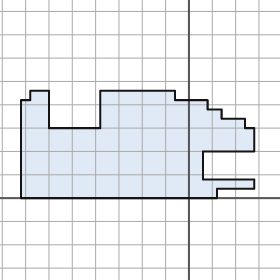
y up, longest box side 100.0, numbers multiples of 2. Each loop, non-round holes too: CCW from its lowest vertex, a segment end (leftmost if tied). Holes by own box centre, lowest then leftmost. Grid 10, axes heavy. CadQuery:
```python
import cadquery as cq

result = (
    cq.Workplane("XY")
    .moveTo(-72.0, 0.0)
    .lineTo(12.0, 0.0)
    .lineTo(12.0, 4.0)
    .lineTo(28.0, 4.0)
    .lineTo(28.0, 8.0)
    .lineTo(6.0, 8.0)
    .lineTo(6.0, 20.0)
    .lineTo(28.0, 20.0)
    .lineTo(28.0, 30.0)
    .lineTo(24.0, 30.0)
    .lineTo(24.0, 34.0)
    .lineTo(14.0, 34.0)
    .lineTo(14.0, 38.0)
    .lineTo(8.0, 38.0)
    .lineTo(8.0, 42.0)
    .lineTo(-6.0, 42.0)
    .lineTo(-6.0, 46.0)
    .lineTo(-38.0, 46.0)
    .lineTo(-38.0, 30.0)
    .lineTo(-60.0, 30.0)
    .lineTo(-60.0, 46.0)
    .lineTo(-68.0, 46.0)
    .lineTo(-68.0, 42.0)
    .lineTo(-72.0, 42.0)
    .close()
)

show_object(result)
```